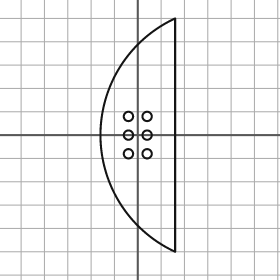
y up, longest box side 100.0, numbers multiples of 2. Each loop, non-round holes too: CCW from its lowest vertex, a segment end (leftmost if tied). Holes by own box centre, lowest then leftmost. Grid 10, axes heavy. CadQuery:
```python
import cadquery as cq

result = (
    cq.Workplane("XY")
    .moveTo(16.0, -50.0)
    .lineTo(16.0, 50.0)
    .threePointArc((-16.0, 0.0), (16.0, -50.0))
    .close()
    .moveTo(-4.0, -8.0)
    .circle(2.0)
    .moveTo(4.0, -8.0)
    .circle(2.0)
    .moveTo(-4.0, 0.0)
    .circle(2.0)
    .moveTo(4.0, 0.0)
    .circle(2.0)
    .moveTo(-4.0, 8.0)
    .circle(2.0)
    .moveTo(4.0, 8.0)
    .circle(2.0)
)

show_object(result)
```